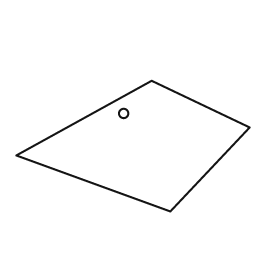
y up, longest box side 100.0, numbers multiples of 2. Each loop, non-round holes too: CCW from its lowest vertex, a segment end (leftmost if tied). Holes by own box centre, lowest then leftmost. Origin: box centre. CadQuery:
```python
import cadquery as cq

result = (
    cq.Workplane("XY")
    .moveTo(16.0, -28.0)
    .lineTo(50.0, 8.0)
    .lineTo(8.0, 28.0)
    .lineTo(-50.0, -4.0)
    .close()
    .moveTo(-4.0, 14.0)
    .circle(2.0)
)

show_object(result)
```